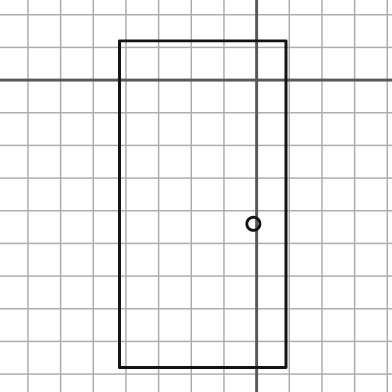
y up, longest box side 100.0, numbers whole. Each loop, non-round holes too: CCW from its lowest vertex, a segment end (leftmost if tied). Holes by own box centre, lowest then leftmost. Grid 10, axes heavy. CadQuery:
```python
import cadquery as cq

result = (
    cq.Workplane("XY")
    .moveTo(-42.0, -88.0)
    .lineTo(9.0, -88.0)
    .lineTo(9.0, 12.0)
    .lineTo(-42.0, 12.0)
    .close()
    .moveTo(-1.0, -44.0)
    .circle(2.0)
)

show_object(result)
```